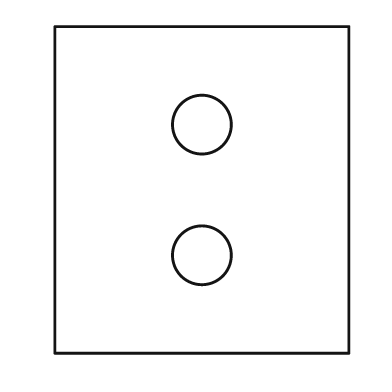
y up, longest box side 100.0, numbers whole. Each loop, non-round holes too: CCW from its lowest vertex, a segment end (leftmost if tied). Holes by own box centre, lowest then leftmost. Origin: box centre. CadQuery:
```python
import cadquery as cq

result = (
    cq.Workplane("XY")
    .moveTo(-45.0, -50.0)
    .lineTo(45.0, -50.0)
    .lineTo(45.0, 50.0)
    .lineTo(-45.0, 50.0)
    .close()
    .moveTo(0.0, -20.0)
    .circle(9.0)
    .moveTo(0.0, 20.0)
    .circle(9.0)
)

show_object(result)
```